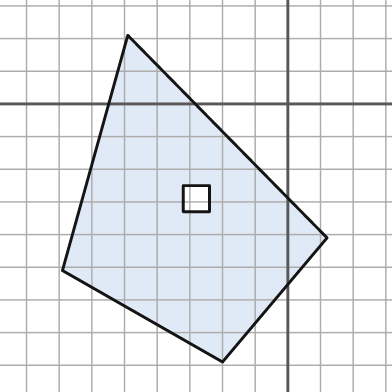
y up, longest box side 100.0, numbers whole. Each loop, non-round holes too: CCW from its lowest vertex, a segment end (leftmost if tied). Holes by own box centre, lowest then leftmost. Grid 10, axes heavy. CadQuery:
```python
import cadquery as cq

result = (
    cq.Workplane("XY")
    .moveTo(-20.0, -79.0)
    .lineTo(12.0, -41.0)
    .lineTo(-49.0, 21.0)
    .lineTo(-69.0, -51.0)
    .close()
    .moveTo(-32.0, -33.0)
    .lineTo(-24.0, -33.0)
    .lineTo(-24.0, -25.0)
    .lineTo(-32.0, -25.0)
    .close()
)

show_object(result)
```